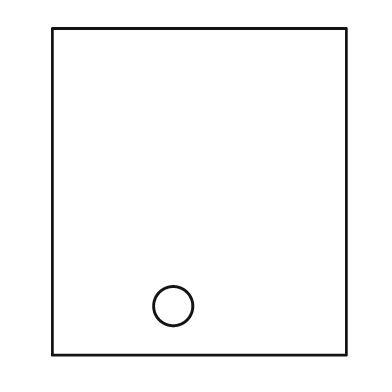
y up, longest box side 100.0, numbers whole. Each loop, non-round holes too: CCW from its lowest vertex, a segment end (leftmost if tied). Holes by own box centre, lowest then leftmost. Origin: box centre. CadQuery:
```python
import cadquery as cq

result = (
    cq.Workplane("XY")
    .moveTo(-45.0, -50.0)
    .lineTo(45.0, -50.0)
    .lineTo(45.0, 50.0)
    .lineTo(-45.0, 50.0)
    .close()
    .moveTo(-8.0, -35.0)
    .circle(6.0)
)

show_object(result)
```